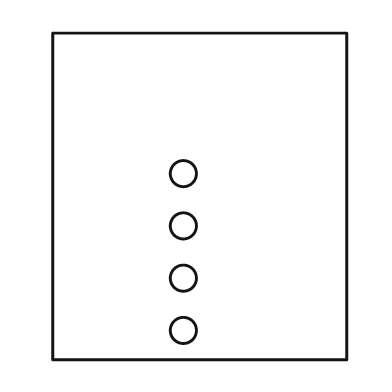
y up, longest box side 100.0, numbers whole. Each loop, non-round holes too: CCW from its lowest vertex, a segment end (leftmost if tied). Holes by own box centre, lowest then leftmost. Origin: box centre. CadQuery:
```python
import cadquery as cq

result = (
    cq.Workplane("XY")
    .moveTo(-45.0, -50.0)
    .lineTo(45.0, -50.0)
    .lineTo(45.0, 50.0)
    .lineTo(-45.0, 50.0)
    .close()
    .moveTo(-5.0, -41.0)
    .circle(4.0)
    .moveTo(-5.0, -25.0)
    .circle(4.0)
    .moveTo(-5.0, -9.0)
    .circle(4.0)
    .moveTo(-5.0, 7.0)
    .circle(4.0)
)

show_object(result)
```